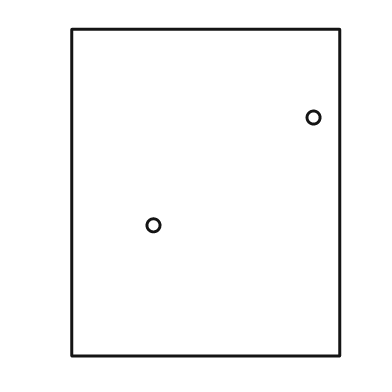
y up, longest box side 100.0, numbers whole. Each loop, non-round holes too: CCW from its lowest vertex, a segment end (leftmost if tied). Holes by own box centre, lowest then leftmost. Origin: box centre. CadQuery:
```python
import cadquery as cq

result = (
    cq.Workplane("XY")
    .moveTo(-41.0, -50.0)
    .lineTo(41.0, -50.0)
    .lineTo(41.0, 50.0)
    .lineTo(-41.0, 50.0)
    .close()
    .moveTo(-16.0, -10.0)
    .circle(2.0)
    .moveTo(33.0, 23.0)
    .circle(2.0)
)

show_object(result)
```